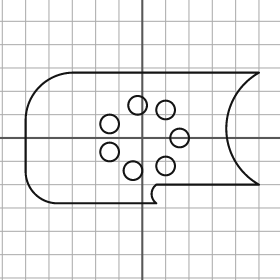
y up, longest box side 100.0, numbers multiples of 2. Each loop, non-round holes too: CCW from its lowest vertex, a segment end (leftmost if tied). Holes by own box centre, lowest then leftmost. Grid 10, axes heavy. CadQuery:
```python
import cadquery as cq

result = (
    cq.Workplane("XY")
    .moveTo(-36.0, -28.0)
    .lineTo(6.0, -28.0)
    .threePointArc((4.0, -24.0), (6.0, -20.0))
    .lineTo(50.0, -20.0)
    .threePointArc((36.0, 4.0), (50.0, 28.0))
    .lineTo(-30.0, 28.0)
    .threePointArc((-44.0, 22.0), (-50.0, 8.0))
    .lineTo(-50.0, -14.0)
    .threePointArc((-46.0, -24.0), (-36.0, -28.0))
    .close()
    .moveTo(-4.0, -14.0)
    .circle(4.0)
    .moveTo(10.0, -12.0)
    .circle(4.0)
    .moveTo(-14.0, -6.0)
    .circle(4.0)
    .moveTo(16.0, 0.0)
    .circle(4.0)
    .moveTo(-14.0, 6.0)
    .circle(4.0)
    .moveTo(10.0, 12.0)
    .circle(4.0)
    .moveTo(-2.0, 14.0)
    .circle(4.0)
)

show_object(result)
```